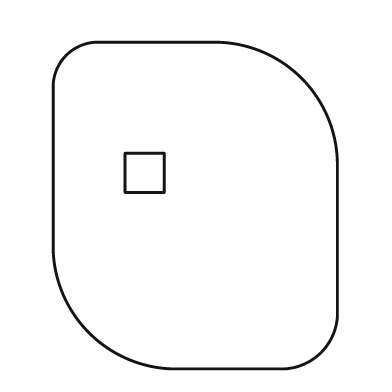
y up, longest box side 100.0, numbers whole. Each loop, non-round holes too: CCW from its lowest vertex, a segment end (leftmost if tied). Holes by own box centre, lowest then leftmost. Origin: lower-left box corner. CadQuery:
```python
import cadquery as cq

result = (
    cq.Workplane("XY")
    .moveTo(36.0, 0.0)
    .lineTo(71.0, 0.0)
    .threePointArc((82.0, 5.0), (87.0, 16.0))
    .lineTo(87.0, 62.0)
    .threePointArc((76.0, 89.0), (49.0, 100.0))
    .lineTo(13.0, 100.0)
    .threePointArc((4.0, 96.0), (0.0, 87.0))
    .lineTo(0.0, 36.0)
    .threePointArc((11.0, 11.0), (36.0, 0.0))
    .close()
    .moveTo(22.0, 54.0)
    .lineTo(34.0, 54.0)
    .lineTo(34.0, 66.0)
    .lineTo(22.0, 66.0)
    .close()
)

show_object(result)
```